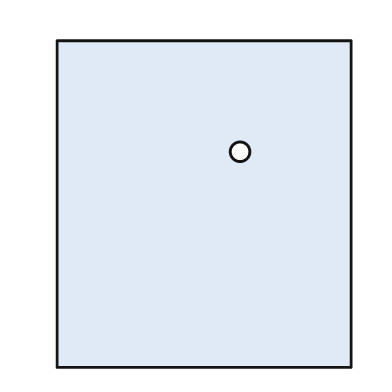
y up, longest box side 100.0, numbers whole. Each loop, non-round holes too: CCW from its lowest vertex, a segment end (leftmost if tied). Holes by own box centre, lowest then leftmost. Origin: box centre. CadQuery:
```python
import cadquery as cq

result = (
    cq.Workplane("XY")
    .moveTo(-45.0, -50.0)
    .lineTo(45.0, -50.0)
    .lineTo(45.0, 50.0)
    .lineTo(-45.0, 50.0)
    .close()
    .moveTo(11.0, 16.0)
    .circle(3.0)
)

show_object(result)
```